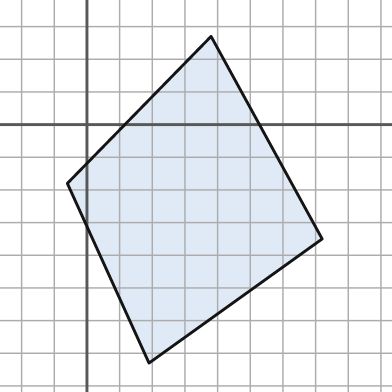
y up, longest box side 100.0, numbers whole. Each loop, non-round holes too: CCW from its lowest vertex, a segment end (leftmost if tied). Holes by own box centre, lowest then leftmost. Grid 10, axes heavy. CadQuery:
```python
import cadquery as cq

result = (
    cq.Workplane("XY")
    .moveTo(19.0, -73.0)
    .lineTo(72.0, -35.0)
    .lineTo(38.0, 27.0)
    .lineTo(-6.0, -18.0)
    .close()
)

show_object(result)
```